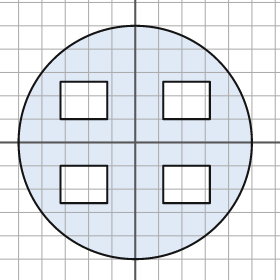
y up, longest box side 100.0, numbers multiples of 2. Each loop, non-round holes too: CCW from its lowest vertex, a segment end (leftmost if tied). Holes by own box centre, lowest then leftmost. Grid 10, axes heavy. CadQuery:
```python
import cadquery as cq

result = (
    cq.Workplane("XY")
    .moveTo(0.0, 0.0)
    .circle(50.0)
    .moveTo(-32.0, -26.0)
    .lineTo(-12.0, -26.0)
    .lineTo(-12.0, -10.0)
    .lineTo(-32.0, -10.0)
    .close()
    .moveTo(12.0, -26.0)
    .lineTo(32.0, -26.0)
    .lineTo(32.0, -10.0)
    .lineTo(12.0, -10.0)
    .close()
    .moveTo(-32.0, 10.0)
    .lineTo(-12.0, 10.0)
    .lineTo(-12.0, 26.0)
    .lineTo(-32.0, 26.0)
    .close()
    .moveTo(12.0, 10.0)
    .lineTo(32.0, 10.0)
    .lineTo(32.0, 26.0)
    .lineTo(12.0, 26.0)
    .close()
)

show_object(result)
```